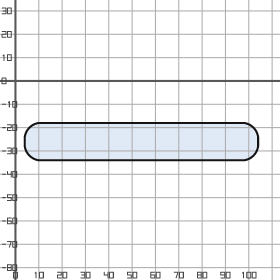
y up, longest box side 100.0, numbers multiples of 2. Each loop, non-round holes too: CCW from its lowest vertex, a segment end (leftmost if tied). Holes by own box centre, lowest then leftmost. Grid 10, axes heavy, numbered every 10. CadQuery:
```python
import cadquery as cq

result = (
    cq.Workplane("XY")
    .moveTo(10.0, -34.0)
    .lineTo(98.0, -34.0)
    .threePointArc((102.0, -32.0), (104.0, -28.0))
    .lineTo(104.0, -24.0)
    .threePointArc((102.0, -20.0), (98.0, -18.0))
    .lineTo(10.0, -18.0)
    .threePointArc((6.0, -20.0), (4.0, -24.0))
    .lineTo(4.0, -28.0)
    .threePointArc((6.0, -32.0), (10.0, -34.0))
    .close()
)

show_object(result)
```